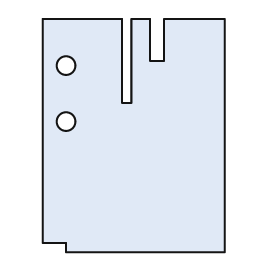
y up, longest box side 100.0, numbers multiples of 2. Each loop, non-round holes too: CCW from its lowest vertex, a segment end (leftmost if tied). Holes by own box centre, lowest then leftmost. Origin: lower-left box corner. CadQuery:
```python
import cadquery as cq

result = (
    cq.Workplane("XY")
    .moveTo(10.0, 0.0)
    .lineTo(78.0, 0.0)
    .lineTo(78.0, 100.0)
    .lineTo(52.0, 100.0)
    .lineTo(52.0, 82.0)
    .lineTo(46.0, 82.0)
    .lineTo(46.0, 100.0)
    .lineTo(38.0, 100.0)
    .lineTo(38.0, 64.0)
    .lineTo(34.0, 64.0)
    .lineTo(34.0, 100.0)
    .lineTo(0.0, 100.0)
    .lineTo(0.0, 4.0)
    .lineTo(10.0, 4.0)
    .close()
    .moveTo(10.0, 56.0)
    .circle(4.0)
    .moveTo(10.0, 80.0)
    .circle(4.0)
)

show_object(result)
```